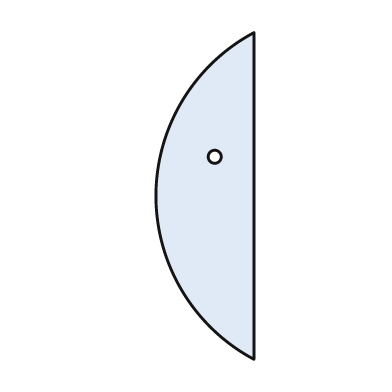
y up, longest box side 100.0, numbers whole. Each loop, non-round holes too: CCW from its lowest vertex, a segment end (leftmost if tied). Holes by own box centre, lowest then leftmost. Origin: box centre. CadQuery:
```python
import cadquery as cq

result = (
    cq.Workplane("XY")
    .moveTo(15.0, -50.0)
    .lineTo(15.0, 50.0)
    .threePointArc((-15.0, 0.0), (15.0, -50.0))
    .close()
    .moveTo(3.0, 12.0)
    .circle(2.0)
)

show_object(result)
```